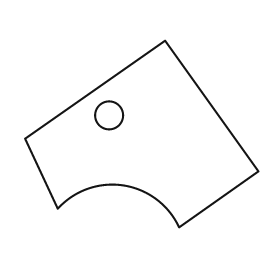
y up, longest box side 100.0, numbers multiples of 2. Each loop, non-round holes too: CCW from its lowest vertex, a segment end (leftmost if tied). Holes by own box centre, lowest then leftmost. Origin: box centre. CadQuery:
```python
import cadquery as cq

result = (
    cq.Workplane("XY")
    .moveTo(16.0, -40.0)
    .lineTo(50.0, -16.0)
    .lineTo(10.0, 40.0)
    .lineTo(-50.0, -2.0)
    .lineTo(-36.0, -32.0)
    .threePointArc((-8.0, -22.0), (16.0, -40.0))
    .close()
    .moveTo(-14.0, 8.0)
    .circle(6.0)
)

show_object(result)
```